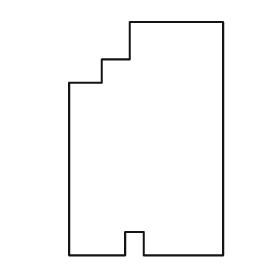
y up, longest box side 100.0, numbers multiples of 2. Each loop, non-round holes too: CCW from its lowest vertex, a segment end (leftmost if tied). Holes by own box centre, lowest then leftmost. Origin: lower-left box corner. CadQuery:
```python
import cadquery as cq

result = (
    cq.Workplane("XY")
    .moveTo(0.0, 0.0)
    .lineTo(24.0, 0.0)
    .lineTo(24.0, 10.0)
    .lineTo(32.0, 10.0)
    .lineTo(32.0, 0.0)
    .lineTo(66.0, 0.0)
    .lineTo(66.0, 100.0)
    .lineTo(26.0, 100.0)
    .lineTo(26.0, 84.0)
    .lineTo(14.0, 84.0)
    .lineTo(14.0, 74.0)
    .lineTo(0.0, 74.0)
    .close()
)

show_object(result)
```